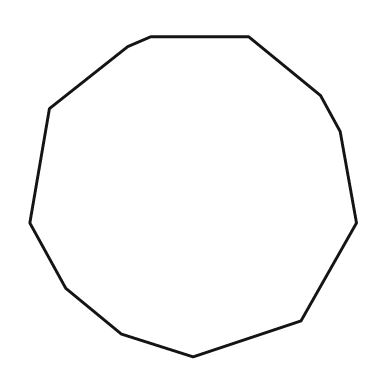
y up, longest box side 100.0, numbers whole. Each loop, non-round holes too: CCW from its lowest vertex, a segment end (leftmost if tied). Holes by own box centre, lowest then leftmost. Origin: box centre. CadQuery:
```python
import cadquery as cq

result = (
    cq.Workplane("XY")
    .moveTo(0.0, -49.0)
    .lineTo(33.0, -38.0)
    .lineTo(50.0, -8.0)
    .lineTo(45.0, 20.0)
    .lineTo(39.0, 31.0)
    .lineTo(17.0, 49.0)
    .lineTo(-13.0, 49.0)
    .lineTo(-20.0, 46.0)
    .lineTo(-44.0, 27.0)
    .lineTo(-50.0, -8.0)
    .lineTo(-39.0, -28.0)
    .lineTo(-22.0, -42.0)
    .close()
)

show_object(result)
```